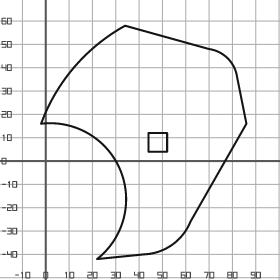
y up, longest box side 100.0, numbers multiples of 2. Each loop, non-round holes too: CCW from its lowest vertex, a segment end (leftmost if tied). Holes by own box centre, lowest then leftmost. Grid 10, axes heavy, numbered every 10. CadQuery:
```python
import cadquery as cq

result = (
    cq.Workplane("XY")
    .moveTo(22.0, -42.0)
    .lineTo(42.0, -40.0)
    .threePointArc((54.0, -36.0), (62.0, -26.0))
    .lineTo(86.0, 16.0)
    .lineTo(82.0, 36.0)
    .threePointArc((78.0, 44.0), (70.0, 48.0))
    .lineTo(34.0, 58.0)
    .threePointArc((12.0, 40.0), (-2.0, 16.0))
    .threePointArc((32.0, -4.0), (22.0, -42.0))
    .close()
    .moveTo(44.0, 4.0)
    .lineTo(52.0, 4.0)
    .lineTo(52.0, 12.0)
    .lineTo(44.0, 12.0)
    .close()
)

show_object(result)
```